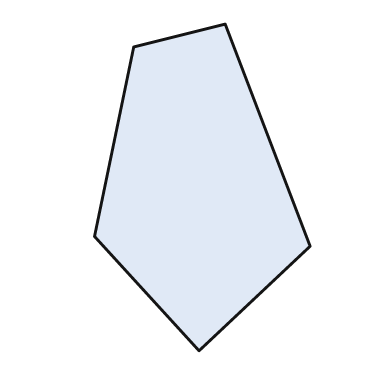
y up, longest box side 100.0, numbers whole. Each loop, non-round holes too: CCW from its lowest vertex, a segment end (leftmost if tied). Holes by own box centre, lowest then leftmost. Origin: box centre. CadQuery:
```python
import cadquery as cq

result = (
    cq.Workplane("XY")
    .moveTo(-1.0, -50.0)
    .lineTo(33.0, -18.0)
    .lineTo(7.0, 50.0)
    .lineTo(-21.0, 43.0)
    .lineTo(-33.0, -15.0)
    .close()
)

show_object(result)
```